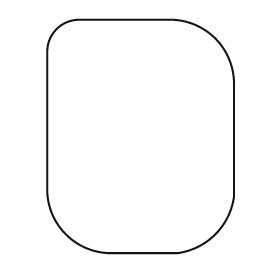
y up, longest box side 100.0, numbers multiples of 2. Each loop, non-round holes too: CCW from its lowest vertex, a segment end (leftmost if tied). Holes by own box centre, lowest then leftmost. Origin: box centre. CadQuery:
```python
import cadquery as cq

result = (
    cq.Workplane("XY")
    .moveTo(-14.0, -50.0)
    .lineTo(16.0, -50.0)
    .threePointArc((32.0, -42.0), (40.0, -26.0))
    .lineTo(40.0, 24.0)
    .threePointArc((32.0, 42.0), (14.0, 50.0))
    .lineTo(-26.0, 50.0)
    .threePointArc((-36.0, 46.0), (-40.0, 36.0))
    .lineTo(-40.0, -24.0)
    .threePointArc((-32.0, -42.0), (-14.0, -50.0))
    .close()
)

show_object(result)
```